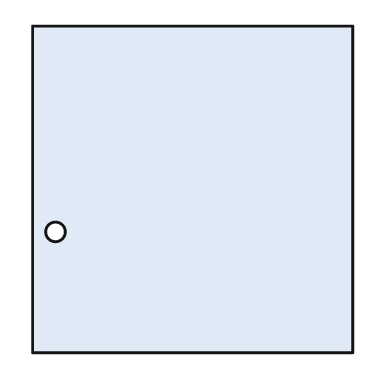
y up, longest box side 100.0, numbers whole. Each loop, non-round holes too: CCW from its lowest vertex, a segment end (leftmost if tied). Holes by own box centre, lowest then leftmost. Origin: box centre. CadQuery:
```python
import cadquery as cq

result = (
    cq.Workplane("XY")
    .moveTo(-49.0, -50.0)
    .lineTo(49.0, -50.0)
    .lineTo(49.0, 50.0)
    .lineTo(-49.0, 50.0)
    .close()
    .moveTo(-42.0, -13.0)
    .circle(3.0)
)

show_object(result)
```